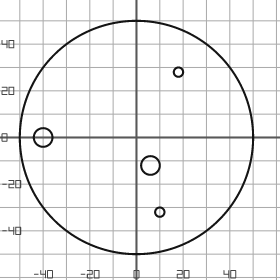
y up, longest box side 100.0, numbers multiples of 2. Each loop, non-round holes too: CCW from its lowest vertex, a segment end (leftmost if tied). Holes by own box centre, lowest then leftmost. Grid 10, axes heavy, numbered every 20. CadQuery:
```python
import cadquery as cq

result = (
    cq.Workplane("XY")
    .moveTo(0.0, 0.0)
    .circle(50.0)
    .moveTo(10.0, -32.0)
    .circle(2.0)
    .moveTo(6.0, -12.0)
    .circle(4.0)
    .moveTo(-40.0, 0.0)
    .circle(4.0)
    .moveTo(18.0, 28.0)
    .circle(2.0)
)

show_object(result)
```